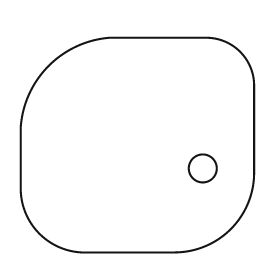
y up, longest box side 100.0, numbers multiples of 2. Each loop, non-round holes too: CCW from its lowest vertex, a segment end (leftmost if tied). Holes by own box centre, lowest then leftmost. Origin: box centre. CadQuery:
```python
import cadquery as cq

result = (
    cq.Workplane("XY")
    .moveTo(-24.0, -46.0)
    .lineTo(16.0, -46.0)
    .threePointArc((40.0, -36.0), (50.0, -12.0))
    .lineTo(50.0, 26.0)
    .threePointArc((44.0, 40.0), (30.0, 46.0))
    .lineTo(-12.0, 46.0)
    .threePointArc((-38.0, 34.0), (-50.0, 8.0))
    .lineTo(-50.0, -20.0)
    .threePointArc((-42.0, -38.0), (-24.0, -46.0))
    .close()
    .moveTo(28.0, -10.0)
    .circle(6.0)
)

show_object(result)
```